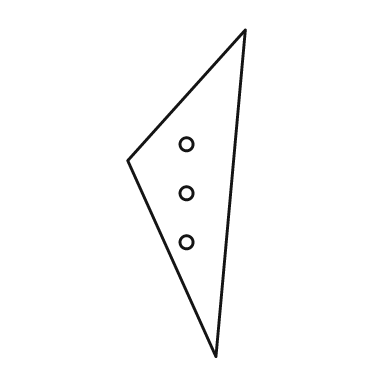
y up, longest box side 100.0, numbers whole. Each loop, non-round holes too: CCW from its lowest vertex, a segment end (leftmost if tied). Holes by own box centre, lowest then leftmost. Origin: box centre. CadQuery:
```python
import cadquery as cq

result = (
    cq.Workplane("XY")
    .moveTo(9.0, -50.0)
    .lineTo(18.0, 50.0)
    .lineTo(-18.0, 10.0)
    .close()
    .moveTo(0.0, -15.0)
    .circle(2.0)
    .moveTo(0.0, 0.0)
    .circle(2.0)
    .moveTo(0.0, 15.0)
    .circle(2.0)
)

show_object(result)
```